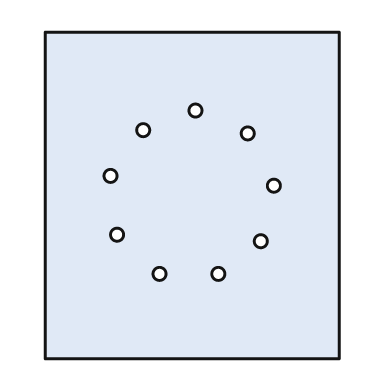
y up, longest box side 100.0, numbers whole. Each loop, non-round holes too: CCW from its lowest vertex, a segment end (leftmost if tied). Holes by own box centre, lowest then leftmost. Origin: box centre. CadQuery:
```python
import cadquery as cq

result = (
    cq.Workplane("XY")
    .moveTo(-45.0, -50.0)
    .lineTo(45.0, -50.0)
    .lineTo(45.0, 50.0)
    .lineTo(-45.0, 50.0)
    .close()
    .moveTo(-10.0, -24.0)
    .circle(2.0)
    .moveTo(8.0, -24.0)
    .circle(2.0)
    .moveTo(21.0, -14.0)
    .circle(2.0)
    .moveTo(-23.0, -12.0)
    .circle(2.0)
    .moveTo(25.0, 3.0)
    .circle(2.0)
    .moveTo(-25.0, 6.0)
    .circle(2.0)
    .moveTo(17.0, 19.0)
    .circle(2.0)
    .moveTo(-15.0, 20.0)
    .circle(2.0)
    .moveTo(1.0, 26.0)
    .circle(2.0)
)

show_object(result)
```